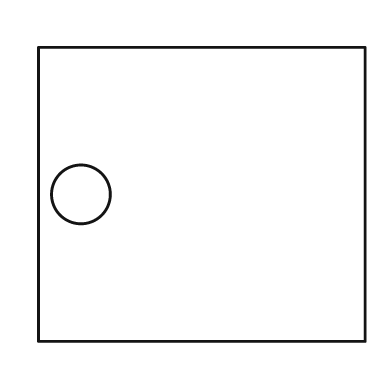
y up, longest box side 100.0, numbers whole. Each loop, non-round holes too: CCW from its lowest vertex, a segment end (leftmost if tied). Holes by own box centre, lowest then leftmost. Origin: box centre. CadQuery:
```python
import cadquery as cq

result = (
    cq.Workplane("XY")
    .moveTo(-50.0, -45.0)
    .lineTo(50.0, -45.0)
    .lineTo(50.0, 45.0)
    .lineTo(-50.0, 45.0)
    .close()
    .moveTo(-37.0, 0.0)
    .circle(9.0)
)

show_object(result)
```